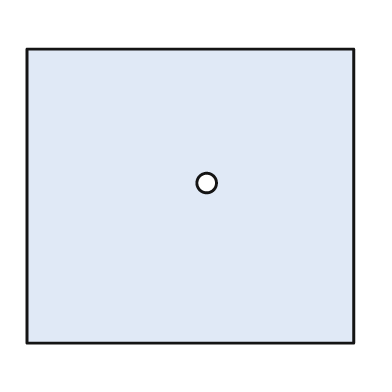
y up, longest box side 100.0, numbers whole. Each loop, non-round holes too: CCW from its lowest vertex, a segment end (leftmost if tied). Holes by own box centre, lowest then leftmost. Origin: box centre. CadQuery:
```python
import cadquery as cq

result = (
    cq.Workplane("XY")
    .moveTo(-50.0, -45.0)
    .lineTo(50.0, -45.0)
    .lineTo(50.0, 45.0)
    .lineTo(-50.0, 45.0)
    .close()
    .moveTo(5.0, 4.0)
    .circle(3.0)
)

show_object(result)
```